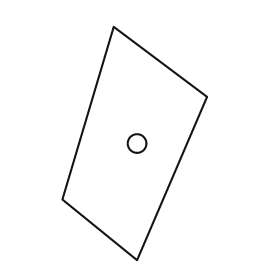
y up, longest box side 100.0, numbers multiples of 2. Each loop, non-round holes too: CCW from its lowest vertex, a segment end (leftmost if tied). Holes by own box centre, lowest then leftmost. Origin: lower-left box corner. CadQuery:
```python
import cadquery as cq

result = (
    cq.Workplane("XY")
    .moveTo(32.0, 0.0)
    .lineTo(62.0, 70.0)
    .lineTo(22.0, 100.0)
    .lineTo(0.0, 26.0)
    .close()
    .moveTo(32.0, 50.0)
    .circle(4.0)
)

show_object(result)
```